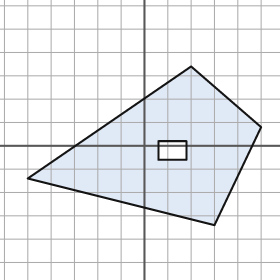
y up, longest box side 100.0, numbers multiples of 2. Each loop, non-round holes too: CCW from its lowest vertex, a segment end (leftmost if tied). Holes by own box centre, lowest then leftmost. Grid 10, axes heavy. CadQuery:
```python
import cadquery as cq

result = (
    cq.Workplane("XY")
    .moveTo(30.0, -34.0)
    .lineTo(50.0, 8.0)
    .lineTo(20.0, 34.0)
    .lineTo(-50.0, -14.0)
    .close()
    .moveTo(6.0, -6.0)
    .lineTo(18.0, -6.0)
    .lineTo(18.0, 2.0)
    .lineTo(6.0, 2.0)
    .close()
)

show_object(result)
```